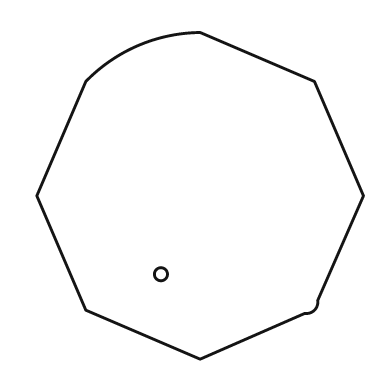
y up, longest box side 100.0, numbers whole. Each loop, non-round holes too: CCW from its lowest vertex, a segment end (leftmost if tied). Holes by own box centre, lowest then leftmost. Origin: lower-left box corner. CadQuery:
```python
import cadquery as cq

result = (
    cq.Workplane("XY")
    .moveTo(50.0, 0.0)
    .lineTo(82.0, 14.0)
    .threePointArc((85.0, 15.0), (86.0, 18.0))
    .lineTo(100.0, 50.0)
    .lineTo(85.0, 85.0)
    .lineTo(50.0, 100.0)
    .threePointArc((31.0, 96.0), (15.0, 85.0))
    .lineTo(0.0, 50.0)
    .lineTo(15.0, 15.0)
    .close()
    .moveTo(38.0, 26.0)
    .circle(2.0)
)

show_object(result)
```